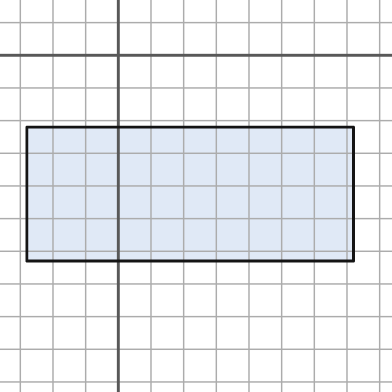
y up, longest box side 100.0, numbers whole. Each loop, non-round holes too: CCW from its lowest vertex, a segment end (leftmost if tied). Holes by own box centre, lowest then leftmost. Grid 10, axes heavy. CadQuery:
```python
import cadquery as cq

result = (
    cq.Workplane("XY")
    .moveTo(-28.0, -63.0)
    .lineTo(72.0, -63.0)
    .lineTo(72.0, -22.0)
    .lineTo(-28.0, -22.0)
    .close()
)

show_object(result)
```